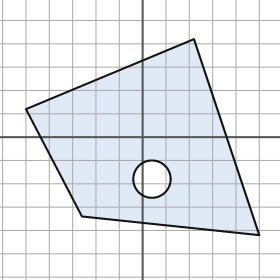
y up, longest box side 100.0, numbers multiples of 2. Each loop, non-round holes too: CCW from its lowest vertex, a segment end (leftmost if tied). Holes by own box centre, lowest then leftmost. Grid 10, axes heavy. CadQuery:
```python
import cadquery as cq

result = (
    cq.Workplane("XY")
    .moveTo(50.0, -42.0)
    .lineTo(22.0, 42.0)
    .lineTo(-50.0, 12.0)
    .lineTo(-26.0, -34.0)
    .close()
    .moveTo(4.0, -18.0)
    .circle(8.0)
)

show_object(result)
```